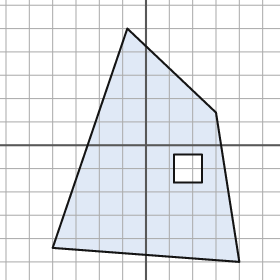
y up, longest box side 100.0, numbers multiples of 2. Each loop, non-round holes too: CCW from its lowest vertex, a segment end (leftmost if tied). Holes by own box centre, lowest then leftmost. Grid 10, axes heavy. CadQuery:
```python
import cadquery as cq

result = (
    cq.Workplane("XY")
    .moveTo(40.0, -50.0)
    .lineTo(30.0, 14.0)
    .lineTo(-8.0, 50.0)
    .lineTo(-40.0, -44.0)
    .close()
    .moveTo(12.0, -16.0)
    .lineTo(24.0, -16.0)
    .lineTo(24.0, -4.0)
    .lineTo(12.0, -4.0)
    .close()
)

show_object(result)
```